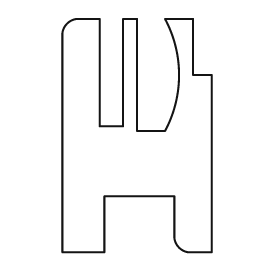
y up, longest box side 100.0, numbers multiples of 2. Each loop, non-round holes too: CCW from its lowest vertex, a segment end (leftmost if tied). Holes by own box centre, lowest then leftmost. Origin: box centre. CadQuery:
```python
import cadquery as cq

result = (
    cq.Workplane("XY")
    .moveTo(-32.0, -50.0)
    .lineTo(-14.0, -50.0)
    .lineTo(-14.0, -26.0)
    .lineTo(16.0, -26.0)
    .lineTo(16.0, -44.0)
    .threePointArc((18.0, -48.0), (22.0, -50.0))
    .lineTo(32.0, -50.0)
    .lineTo(32.0, 26.0)
    .lineTo(24.0, 26.0)
    .lineTo(24.0, 50.0)
    .lineTo(12.0, 50.0)
    .threePointArc((18.0, 26.0), (12.0, 2.0))
    .lineTo(0.0, 2.0)
    .lineTo(0.0, 50.0)
    .lineTo(-6.0, 50.0)
    .lineTo(-6.0, 4.0)
    .lineTo(-16.0, 4.0)
    .lineTo(-16.0, 50.0)
    .lineTo(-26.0, 50.0)
    .threePointArc((-30.0, 48.0), (-32.0, 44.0))
    .close()
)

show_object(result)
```